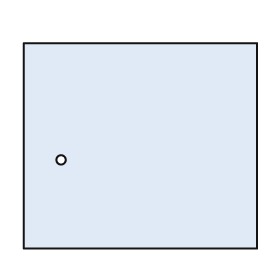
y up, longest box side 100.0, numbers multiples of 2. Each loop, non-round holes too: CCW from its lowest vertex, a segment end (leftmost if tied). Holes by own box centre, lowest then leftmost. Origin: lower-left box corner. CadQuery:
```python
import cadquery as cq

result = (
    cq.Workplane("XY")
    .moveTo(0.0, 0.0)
    .lineTo(100.0, 0.0)
    .lineTo(100.0, 88.0)
    .lineTo(0.0, 88.0)
    .close()
    .moveTo(16.0, 38.0)
    .circle(2.0)
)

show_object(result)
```